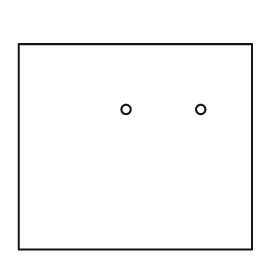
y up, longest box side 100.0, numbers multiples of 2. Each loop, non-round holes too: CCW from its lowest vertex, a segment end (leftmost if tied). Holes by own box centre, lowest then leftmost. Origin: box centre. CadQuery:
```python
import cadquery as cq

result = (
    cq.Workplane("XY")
    .moveTo(-50.0, -44.0)
    .lineTo(50.0, -44.0)
    .lineTo(50.0, 44.0)
    .lineTo(-50.0, 44.0)
    .close()
    .moveTo(-4.0, 16.0)
    .circle(2.0)
    .moveTo(28.0, 16.0)
    .circle(2.0)
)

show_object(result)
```